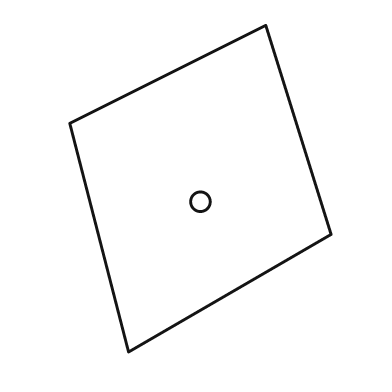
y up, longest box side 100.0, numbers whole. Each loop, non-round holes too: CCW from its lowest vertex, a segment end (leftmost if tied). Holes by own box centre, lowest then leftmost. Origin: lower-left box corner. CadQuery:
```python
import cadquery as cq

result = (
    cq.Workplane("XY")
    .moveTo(18.0, 0.0)
    .lineTo(80.0, 36.0)
    .lineTo(60.0, 100.0)
    .lineTo(0.0, 70.0)
    .close()
    .moveTo(40.0, 46.0)
    .circle(3.0)
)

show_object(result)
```